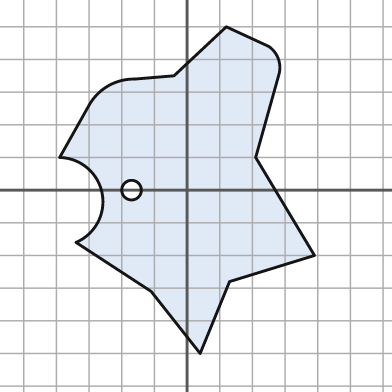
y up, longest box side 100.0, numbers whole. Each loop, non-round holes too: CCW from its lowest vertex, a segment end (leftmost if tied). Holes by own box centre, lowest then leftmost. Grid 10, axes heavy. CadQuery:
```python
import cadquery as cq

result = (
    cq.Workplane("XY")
    .moveTo(4.0, -50.0)
    .lineTo(13.0, -28.0)
    .lineTo(39.0, -20.0)
    .lineTo(21.0, 10.0)
    .lineTo(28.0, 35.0)
    .threePointArc((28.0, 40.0), (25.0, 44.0))
    .lineTo(12.0, 50.0)
    .lineTo(-4.0, 35.0)
    .lineTo(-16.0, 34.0)
    .threePointArc((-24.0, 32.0), (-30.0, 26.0))
    .lineTo(-39.0, 10.0)
    .threePointArc((-26.0, -1.0), (-34.0, -16.0))
    .lineTo(-11.0, -31.0)
    .close()
    .moveTo(-17.0, 0.0)
    .circle(3.0)
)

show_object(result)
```